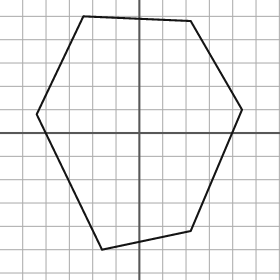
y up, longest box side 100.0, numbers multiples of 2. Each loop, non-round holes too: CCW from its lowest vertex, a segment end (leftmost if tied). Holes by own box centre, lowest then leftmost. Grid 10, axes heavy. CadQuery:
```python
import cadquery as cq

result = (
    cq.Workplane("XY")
    .moveTo(-16.0, -50.0)
    .lineTo(22.0, -42.0)
    .lineTo(44.0, 10.0)
    .lineTo(22.0, 48.0)
    .lineTo(-24.0, 50.0)
    .lineTo(-44.0, 8.0)
    .close()
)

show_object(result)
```